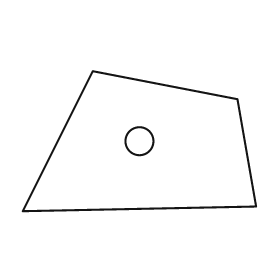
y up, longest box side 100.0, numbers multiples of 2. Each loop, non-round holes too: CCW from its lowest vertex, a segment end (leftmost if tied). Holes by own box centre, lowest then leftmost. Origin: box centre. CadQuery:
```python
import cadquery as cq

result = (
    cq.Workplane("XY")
    .moveTo(-50.0, -30.0)
    .lineTo(50.0, -28.0)
    .lineTo(42.0, 18.0)
    .lineTo(-20.0, 30.0)
    .close()
    .moveTo(0.0, 0.0)
    .circle(6.0)
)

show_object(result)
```